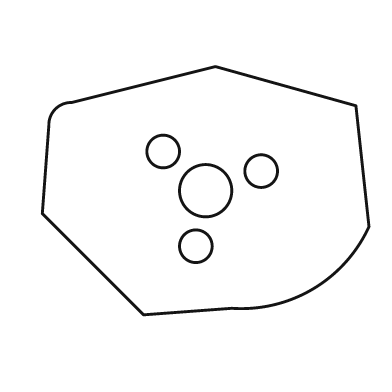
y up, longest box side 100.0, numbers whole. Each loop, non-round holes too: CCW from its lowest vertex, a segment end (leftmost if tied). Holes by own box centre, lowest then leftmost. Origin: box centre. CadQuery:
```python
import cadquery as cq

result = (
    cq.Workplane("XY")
    .moveTo(-19.0, -38.0)
    .lineTo(8.0, -36.0)
    .threePointArc((33.0, -30.0), (50.0, -11.0))
    .lineTo(46.0, 26.0)
    .lineTo(3.0, 38.0)
    .lineTo(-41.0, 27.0)
    .threePointArc((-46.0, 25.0), (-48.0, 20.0))
    .lineTo(-50.0, -7.0)
    .close()
    .moveTo(-3.0, -17.0)
    .circle(5.0)
    .moveTo(0.0, 0.0)
    .circle(8.0)
    .moveTo(17.0, 6.0)
    .circle(5.0)
    .moveTo(-13.0, 12.0)
    .circle(5.0)
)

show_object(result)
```